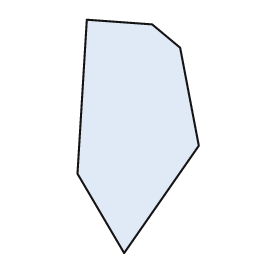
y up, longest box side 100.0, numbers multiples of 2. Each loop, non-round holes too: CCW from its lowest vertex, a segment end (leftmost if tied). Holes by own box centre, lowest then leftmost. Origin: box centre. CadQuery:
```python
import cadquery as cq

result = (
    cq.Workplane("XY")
    .moveTo(-6.0, -50.0)
    .lineTo(26.0, -4.0)
    .lineTo(18.0, 38.0)
    .lineTo(6.0, 48.0)
    .lineTo(-22.0, 50.0)
    .lineTo(-26.0, -16.0)
    .close()
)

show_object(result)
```